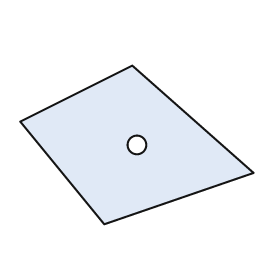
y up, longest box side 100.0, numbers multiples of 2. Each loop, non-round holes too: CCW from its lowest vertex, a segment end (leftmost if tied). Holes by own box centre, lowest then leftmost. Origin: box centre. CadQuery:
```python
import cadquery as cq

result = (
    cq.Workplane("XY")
    .moveTo(-14.0, -34.0)
    .lineTo(50.0, -12.0)
    .lineTo(-2.0, 34.0)
    .lineTo(-50.0, 10.0)
    .close()
    .moveTo(0.0, 0.0)
    .circle(4.0)
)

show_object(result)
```